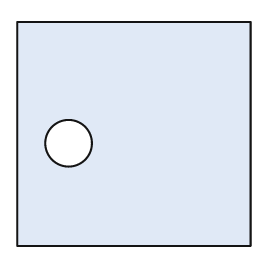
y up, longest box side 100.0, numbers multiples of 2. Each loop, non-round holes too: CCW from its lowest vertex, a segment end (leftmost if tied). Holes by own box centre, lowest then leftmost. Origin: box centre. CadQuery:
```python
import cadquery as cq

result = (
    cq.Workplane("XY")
    .moveTo(-50.0, -48.0)
    .lineTo(50.0, -48.0)
    .lineTo(50.0, 48.0)
    .lineTo(-50.0, 48.0)
    .close()
    .moveTo(-28.0, -4.0)
    .circle(10.0)
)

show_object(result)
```